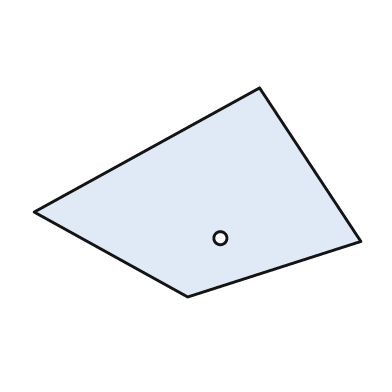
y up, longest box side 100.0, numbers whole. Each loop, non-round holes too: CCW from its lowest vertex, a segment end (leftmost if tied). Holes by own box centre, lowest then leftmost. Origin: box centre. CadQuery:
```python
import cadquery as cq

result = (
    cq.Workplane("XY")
    .moveTo(-3.0, -32.0)
    .lineTo(50.0, -15.0)
    .lineTo(19.0, 32.0)
    .lineTo(-50.0, -6.0)
    .close()
    .moveTo(7.0, -14.0)
    .circle(2.0)
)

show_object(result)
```